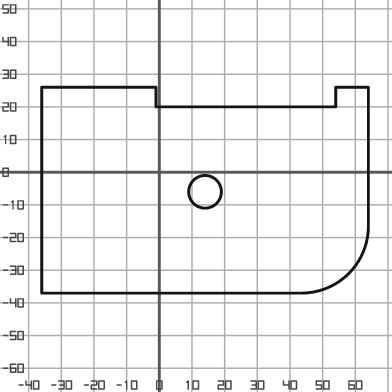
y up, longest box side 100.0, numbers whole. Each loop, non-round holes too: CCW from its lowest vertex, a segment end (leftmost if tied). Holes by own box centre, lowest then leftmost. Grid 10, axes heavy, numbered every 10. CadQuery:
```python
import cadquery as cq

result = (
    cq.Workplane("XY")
    .moveTo(-36.0, -37.0)
    .lineTo(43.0, -37.0)
    .threePointArc((58.0, -31.0), (64.0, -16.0))
    .lineTo(64.0, 26.0)
    .lineTo(54.0, 26.0)
    .lineTo(54.0, 20.0)
    .lineTo(-1.0, 20.0)
    .lineTo(-1.0, 26.0)
    .lineTo(-36.0, 26.0)
    .close()
    .moveTo(14.0, -6.0)
    .circle(5.0)
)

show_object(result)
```